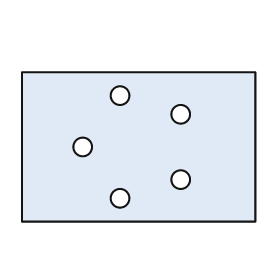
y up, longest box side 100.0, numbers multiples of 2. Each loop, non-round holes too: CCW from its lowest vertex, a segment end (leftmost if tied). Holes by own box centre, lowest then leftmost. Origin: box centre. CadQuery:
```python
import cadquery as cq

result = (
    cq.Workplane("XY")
    .moveTo(-50.0, -32.0)
    .lineTo(50.0, -32.0)
    .lineTo(50.0, 32.0)
    .lineTo(-50.0, 32.0)
    .close()
    .moveTo(-8.0, -22.0)
    .circle(4.0)
    .moveTo(18.0, -14.0)
    .circle(4.0)
    .moveTo(-24.0, 0.0)
    .circle(4.0)
    .moveTo(18.0, 14.0)
    .circle(4.0)
    .moveTo(-8.0, 22.0)
    .circle(4.0)
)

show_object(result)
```